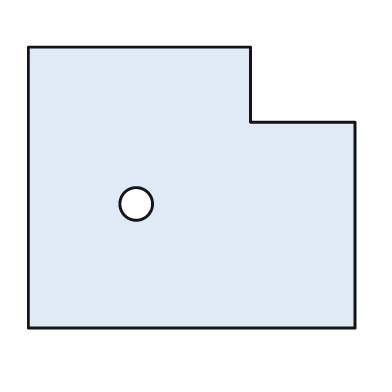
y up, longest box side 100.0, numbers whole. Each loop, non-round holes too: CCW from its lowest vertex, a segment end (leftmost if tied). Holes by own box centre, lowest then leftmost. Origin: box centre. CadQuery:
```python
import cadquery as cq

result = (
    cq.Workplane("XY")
    .moveTo(-50.0, -43.0)
    .lineTo(50.0, -43.0)
    .lineTo(50.0, 20.0)
    .lineTo(18.0, 20.0)
    .lineTo(18.0, 43.0)
    .lineTo(-50.0, 43.0)
    .close()
    .moveTo(-17.0, -5.0)
    .circle(5.0)
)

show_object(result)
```